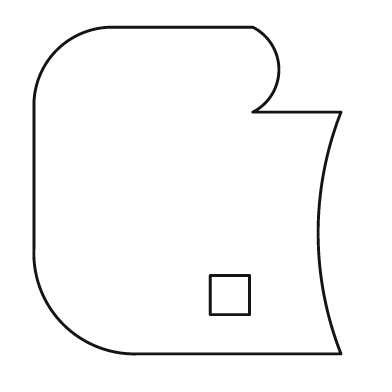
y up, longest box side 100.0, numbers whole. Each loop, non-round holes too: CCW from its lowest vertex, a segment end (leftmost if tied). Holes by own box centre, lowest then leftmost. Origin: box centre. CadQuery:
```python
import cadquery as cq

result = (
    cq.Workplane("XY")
    .moveTo(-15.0, -50.0)
    .lineTo(47.0, -50.0)
    .threePointArc((40.0, -13.0), (47.0, 24.0))
    .lineTo(20.0, 24.0)
    .threePointArc((28.0, 37.0), (20.0, 50.0))
    .lineTo(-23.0, 50.0)
    .threePointArc((-40.0, 43.0), (-47.0, 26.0))
    .lineTo(-47.0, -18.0)
    .threePointArc((-38.0, -41.0), (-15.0, -50.0))
    .close()
    .moveTo(7.0, -38.0)
    .lineTo(19.0, -38.0)
    .lineTo(19.0, -26.0)
    .lineTo(7.0, -26.0)
    .close()
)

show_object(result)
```